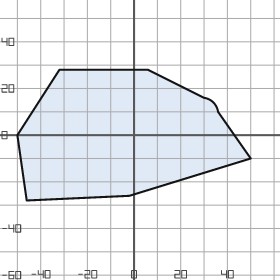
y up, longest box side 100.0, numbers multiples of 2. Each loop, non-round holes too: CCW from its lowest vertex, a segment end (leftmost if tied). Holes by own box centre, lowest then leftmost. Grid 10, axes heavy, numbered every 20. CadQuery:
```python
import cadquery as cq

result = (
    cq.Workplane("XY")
    .moveTo(-46.0, -28.0)
    .lineTo(-2.0, -26.0)
    .lineTo(50.0, -10.0)
    .lineTo(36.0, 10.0)
    .threePointArc((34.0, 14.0), (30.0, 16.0))
    .lineTo(6.0, 28.0)
    .lineTo(-32.0, 28.0)
    .lineTo(-50.0, 0.0)
    .close()
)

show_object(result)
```